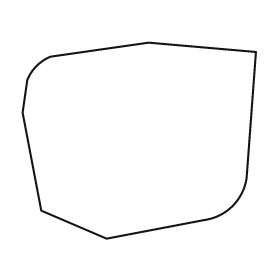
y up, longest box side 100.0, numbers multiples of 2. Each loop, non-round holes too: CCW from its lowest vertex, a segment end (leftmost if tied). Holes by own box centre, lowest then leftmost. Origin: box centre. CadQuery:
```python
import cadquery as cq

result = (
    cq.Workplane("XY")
    .moveTo(-14.0, -42.0)
    .lineTo(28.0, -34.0)
    .threePointArc((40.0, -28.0), (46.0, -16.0))
    .lineTo(50.0, 38.0)
    .lineTo(4.0, 42.0)
    .lineTo(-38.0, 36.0)
    .threePointArc((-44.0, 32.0), (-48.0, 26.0))
    .lineTo(-50.0, 12.0)
    .lineTo(-42.0, -30.0)
    .close()
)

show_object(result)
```